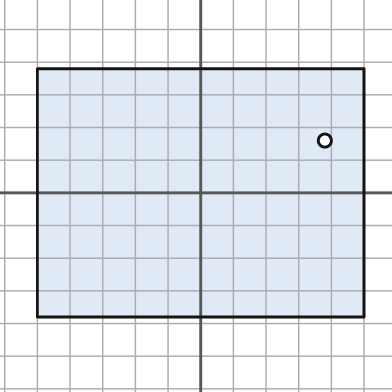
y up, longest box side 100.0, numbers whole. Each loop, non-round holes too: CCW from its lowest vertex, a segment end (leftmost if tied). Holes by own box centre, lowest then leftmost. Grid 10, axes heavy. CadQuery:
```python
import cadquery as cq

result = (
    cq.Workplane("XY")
    .moveTo(-50.0, -38.0)
    .lineTo(50.0, -38.0)
    .lineTo(50.0, 38.0)
    .lineTo(-50.0, 38.0)
    .close()
    .moveTo(38.0, 16.0)
    .circle(2.0)
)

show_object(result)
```